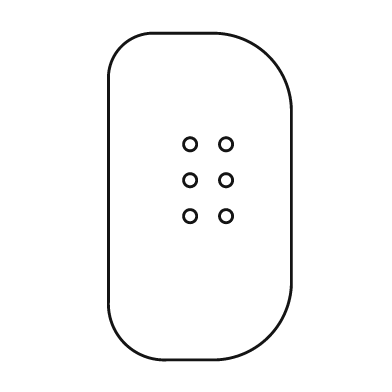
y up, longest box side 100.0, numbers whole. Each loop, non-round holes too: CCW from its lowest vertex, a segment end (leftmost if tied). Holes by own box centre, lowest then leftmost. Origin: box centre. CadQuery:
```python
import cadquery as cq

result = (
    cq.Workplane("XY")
    .moveTo(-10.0, -50.0)
    .lineTo(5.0, -50.0)
    .threePointArc((21.0, -43.0), (28.0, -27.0))
    .lineTo(28.0, 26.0)
    .threePointArc((21.0, 43.0), (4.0, 50.0))
    .lineTo(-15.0, 50.0)
    .threePointArc((-24.0, 46.0), (-28.0, 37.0))
    .lineTo(-28.0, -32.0)
    .threePointArc((-23.0, -45.0), (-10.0, -50.0))
    .close()
    .moveTo(-3.0, -6.0)
    .circle(2.0)
    .moveTo(8.0, -6.0)
    .circle(2.0)
    .moveTo(-3.0, 5.0)
    .circle(2.0)
    .moveTo(8.0, 5.0)
    .circle(2.0)
    .moveTo(-3.0, 16.0)
    .circle(2.0)
    .moveTo(8.0, 16.0)
    .circle(2.0)
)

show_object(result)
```